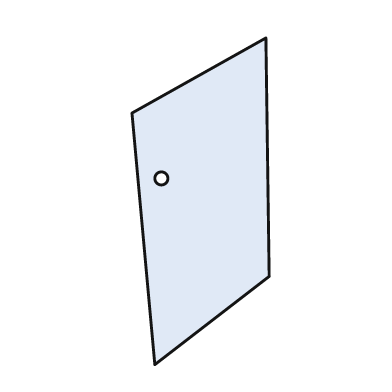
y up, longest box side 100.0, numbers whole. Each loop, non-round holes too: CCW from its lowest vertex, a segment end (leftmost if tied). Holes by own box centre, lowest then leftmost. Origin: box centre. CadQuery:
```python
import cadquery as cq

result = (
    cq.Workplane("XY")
    .moveTo(-14.0, -50.0)
    .lineTo(21.0, -23.0)
    .lineTo(20.0, 50.0)
    .lineTo(-21.0, 27.0)
    .close()
    .moveTo(-12.0, 7.0)
    .circle(2.0)
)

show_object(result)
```